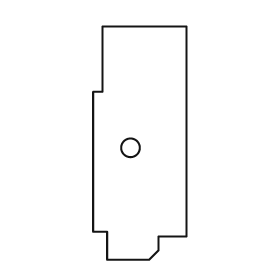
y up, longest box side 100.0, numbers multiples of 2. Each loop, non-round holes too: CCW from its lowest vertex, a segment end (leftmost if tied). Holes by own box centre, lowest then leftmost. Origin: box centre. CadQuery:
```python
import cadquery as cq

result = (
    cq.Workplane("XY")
    .moveTo(-14.0, -50.0)
    .lineTo(4.0, -50.0)
    .lineTo(8.0, -46.0)
    .lineTo(8.0, -40.0)
    .lineTo(20.0, -40.0)
    .lineTo(20.0, 50.0)
    .lineTo(-16.0, 50.0)
    .lineTo(-16.0, 22.0)
    .lineTo(-20.0, 22.0)
    .lineTo(-20.0, -38.0)
    .lineTo(-14.0, -38.0)
    .close()
    .moveTo(-4.0, -2.0)
    .circle(4.0)
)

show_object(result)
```